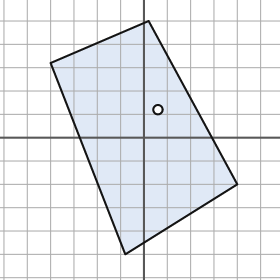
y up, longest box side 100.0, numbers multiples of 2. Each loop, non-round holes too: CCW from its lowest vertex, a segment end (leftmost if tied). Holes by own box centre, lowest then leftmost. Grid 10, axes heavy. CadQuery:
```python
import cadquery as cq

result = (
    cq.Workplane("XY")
    .moveTo(-8.0, -50.0)
    .lineTo(40.0, -20.0)
    .lineTo(2.0, 50.0)
    .lineTo(-40.0, 32.0)
    .close()
    .moveTo(6.0, 12.0)
    .circle(2.0)
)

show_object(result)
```